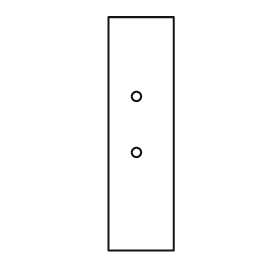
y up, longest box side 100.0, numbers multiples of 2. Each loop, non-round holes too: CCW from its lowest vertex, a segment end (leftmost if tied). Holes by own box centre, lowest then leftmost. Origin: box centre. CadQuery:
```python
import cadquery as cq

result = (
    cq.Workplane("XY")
    .moveTo(-14.0, -50.0)
    .lineTo(14.0, -50.0)
    .lineTo(14.0, 50.0)
    .lineTo(-14.0, 50.0)
    .close()
    .moveTo(-2.0, -8.0)
    .circle(2.0)
    .moveTo(-2.0, 16.0)
    .circle(2.0)
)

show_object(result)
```